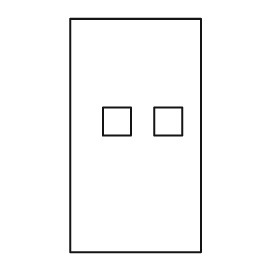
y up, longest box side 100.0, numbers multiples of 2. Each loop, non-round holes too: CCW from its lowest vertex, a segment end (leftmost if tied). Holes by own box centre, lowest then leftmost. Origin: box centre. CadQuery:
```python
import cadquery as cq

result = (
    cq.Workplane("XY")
    .moveTo(-28.0, -50.0)
    .lineTo(28.0, -50.0)
    .lineTo(28.0, 50.0)
    .lineTo(-28.0, 50.0)
    .close()
    .moveTo(-14.0, 0.0)
    .lineTo(-2.0, 0.0)
    .lineTo(-2.0, 12.0)
    .lineTo(-14.0, 12.0)
    .close()
    .moveTo(8.0, 0.0)
    .lineTo(20.0, 0.0)
    .lineTo(20.0, 12.0)
    .lineTo(8.0, 12.0)
    .close()
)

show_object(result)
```